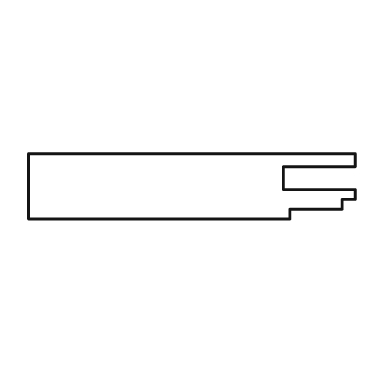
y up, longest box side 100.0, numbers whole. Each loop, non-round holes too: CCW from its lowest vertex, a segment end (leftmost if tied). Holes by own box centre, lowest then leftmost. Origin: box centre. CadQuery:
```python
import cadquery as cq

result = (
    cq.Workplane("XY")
    .moveTo(-50.0, -10.0)
    .lineTo(30.0, -10.0)
    .lineTo(30.0, -7.0)
    .lineTo(46.0, -7.0)
    .lineTo(46.0, -4.0)
    .lineTo(50.0, -4.0)
    .lineTo(50.0, -1.0)
    .lineTo(28.0, -1.0)
    .lineTo(28.0, 6.0)
    .lineTo(50.0, 6.0)
    .lineTo(50.0, 10.0)
    .lineTo(-50.0, 10.0)
    .close()
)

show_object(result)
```